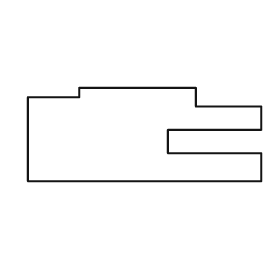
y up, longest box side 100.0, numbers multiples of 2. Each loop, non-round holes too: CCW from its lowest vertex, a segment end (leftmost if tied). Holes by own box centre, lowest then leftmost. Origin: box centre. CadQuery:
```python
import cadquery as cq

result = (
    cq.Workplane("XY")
    .moveTo(-50.0, -20.0)
    .lineTo(50.0, -20.0)
    .lineTo(50.0, -8.0)
    .lineTo(10.0, -8.0)
    .lineTo(10.0, 2.0)
    .lineTo(50.0, 2.0)
    .lineTo(50.0, 12.0)
    .lineTo(22.0, 12.0)
    .lineTo(22.0, 20.0)
    .lineTo(-28.0, 20.0)
    .lineTo(-28.0, 16.0)
    .lineTo(-50.0, 16.0)
    .close()
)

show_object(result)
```